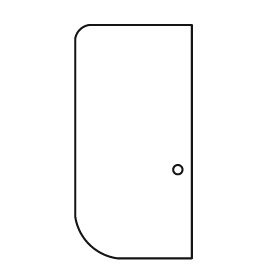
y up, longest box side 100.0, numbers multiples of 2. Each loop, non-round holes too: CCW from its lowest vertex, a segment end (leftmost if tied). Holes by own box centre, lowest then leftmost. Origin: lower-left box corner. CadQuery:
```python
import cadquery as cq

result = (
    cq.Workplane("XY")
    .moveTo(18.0, 0.0)
    .lineTo(50.0, 0.0)
    .lineTo(50.0, 100.0)
    .lineTo(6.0, 100.0)
    .threePointArc((2.0, 98.0), (0.0, 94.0))
    .lineTo(0.0, 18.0)
    .threePointArc((6.0, 6.0), (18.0, 0.0))
    .close()
    .moveTo(44.0, 38.0)
    .circle(2.0)
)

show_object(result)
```